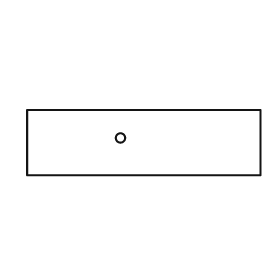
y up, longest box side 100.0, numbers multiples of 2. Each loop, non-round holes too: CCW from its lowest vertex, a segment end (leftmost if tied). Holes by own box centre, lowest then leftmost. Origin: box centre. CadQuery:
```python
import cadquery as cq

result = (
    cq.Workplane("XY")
    .moveTo(-50.0, -14.0)
    .lineTo(50.0, -14.0)
    .lineTo(50.0, 14.0)
    .lineTo(-50.0, 14.0)
    .close()
    .moveTo(-10.0, 2.0)
    .circle(2.0)
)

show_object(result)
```